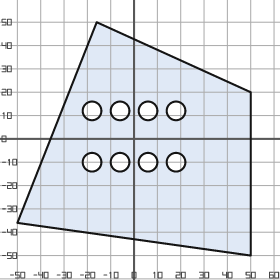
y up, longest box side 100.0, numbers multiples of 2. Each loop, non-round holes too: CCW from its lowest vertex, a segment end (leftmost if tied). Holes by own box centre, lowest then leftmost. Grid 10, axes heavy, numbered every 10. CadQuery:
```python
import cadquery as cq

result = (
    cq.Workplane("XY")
    .moveTo(50.0, -50.0)
    .lineTo(50.0, 20.0)
    .lineTo(-16.0, 50.0)
    .lineTo(-50.0, -36.0)
    .close()
    .moveTo(-18.0, -10.0)
    .circle(4.0)
    .moveTo(-6.0, -10.0)
    .circle(4.0)
    .moveTo(6.0, -10.0)
    .circle(4.0)
    .moveTo(18.0, -10.0)
    .circle(4.0)
    .moveTo(-18.0, 12.0)
    .circle(4.0)
    .moveTo(-6.0, 12.0)
    .circle(4.0)
    .moveTo(6.0, 12.0)
    .circle(4.0)
    .moveTo(18.0, 12.0)
    .circle(4.0)
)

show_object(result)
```